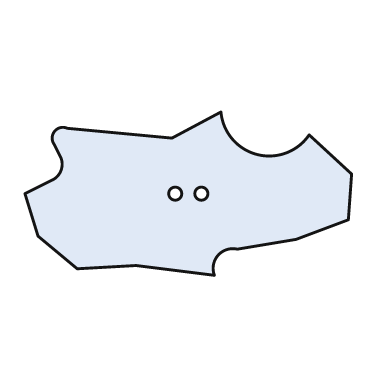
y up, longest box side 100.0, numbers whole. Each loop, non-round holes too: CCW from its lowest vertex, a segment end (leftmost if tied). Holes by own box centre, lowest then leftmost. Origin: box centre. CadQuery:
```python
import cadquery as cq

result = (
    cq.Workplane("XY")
    .moveTo(8.0, -25.0)
    .threePointArc((9.0, -19.0), (15.0, -17.0))
    .lineTo(33.0, -14.0)
    .lineTo(49.0, -8.0)
    .lineTo(50.0, 6.0)
    .lineTo(37.0, 18.0)
    .threePointArc((21.0, 12.0), (10.0, 25.0))
    .lineTo(-5.0, 17.0)
    .lineTo(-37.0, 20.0)
    .threePointArc((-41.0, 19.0), (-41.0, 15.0))
    .lineTo(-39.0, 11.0)
    .threePointArc((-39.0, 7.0), (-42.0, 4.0))
    .lineTo(-50.0, 0.0)
    .lineTo(-46.0, -13.0)
    .lineTo(-34.0, -23.0)
    .lineTo(-16.0, -22.0)
    .close()
    .moveTo(-4.0, 0.0)
    .circle(2.0)
    .moveTo(4.0, 0.0)
    .circle(2.0)
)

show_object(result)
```